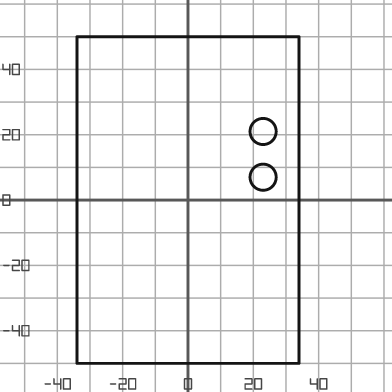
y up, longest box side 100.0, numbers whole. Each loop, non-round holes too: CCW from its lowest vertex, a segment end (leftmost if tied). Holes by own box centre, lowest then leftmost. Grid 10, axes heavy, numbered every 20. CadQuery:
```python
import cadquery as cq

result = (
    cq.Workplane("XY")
    .moveTo(-34.0, -50.0)
    .lineTo(34.0, -50.0)
    .lineTo(34.0, 50.0)
    .lineTo(-34.0, 50.0)
    .close()
    .moveTo(23.0, 7.0)
    .circle(4.0)
    .moveTo(23.0, 21.0)
    .circle(4.0)
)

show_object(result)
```